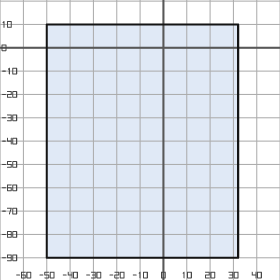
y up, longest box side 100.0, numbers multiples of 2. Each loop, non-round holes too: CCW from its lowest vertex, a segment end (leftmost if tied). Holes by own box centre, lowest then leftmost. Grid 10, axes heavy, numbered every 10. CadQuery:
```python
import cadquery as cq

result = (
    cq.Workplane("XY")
    .moveTo(-50.0, -90.0)
    .lineTo(32.0, -90.0)
    .lineTo(32.0, 10.0)
    .lineTo(-50.0, 10.0)
    .close()
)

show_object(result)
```